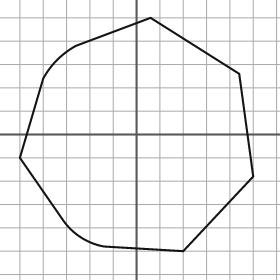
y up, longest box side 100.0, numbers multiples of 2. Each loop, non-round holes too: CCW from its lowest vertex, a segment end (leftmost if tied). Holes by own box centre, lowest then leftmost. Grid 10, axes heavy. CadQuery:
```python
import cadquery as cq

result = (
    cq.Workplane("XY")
    .moveTo(20.0, -50.0)
    .lineTo(50.0, -18.0)
    .lineTo(44.0, 26.0)
    .lineTo(6.0, 50.0)
    .lineTo(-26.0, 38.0)
    .threePointArc((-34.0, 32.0), (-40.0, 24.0))
    .lineTo(-50.0, -10.0)
    .lineTo(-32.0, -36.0)
    .threePointArc((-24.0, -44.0), (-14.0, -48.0))
    .close()
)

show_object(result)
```